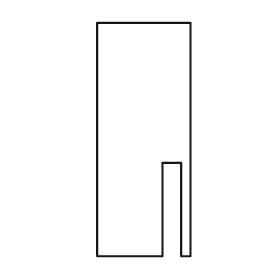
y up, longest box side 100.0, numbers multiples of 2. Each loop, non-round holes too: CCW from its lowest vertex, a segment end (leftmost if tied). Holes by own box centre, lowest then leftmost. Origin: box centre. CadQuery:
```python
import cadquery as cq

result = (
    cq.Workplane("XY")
    .moveTo(-20.0, -50.0)
    .lineTo(8.0, -50.0)
    .lineTo(8.0, -10.0)
    .lineTo(16.0, -10.0)
    .lineTo(16.0, -50.0)
    .lineTo(20.0, -50.0)
    .lineTo(20.0, 50.0)
    .lineTo(-20.0, 50.0)
    .close()
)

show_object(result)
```